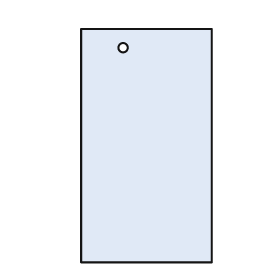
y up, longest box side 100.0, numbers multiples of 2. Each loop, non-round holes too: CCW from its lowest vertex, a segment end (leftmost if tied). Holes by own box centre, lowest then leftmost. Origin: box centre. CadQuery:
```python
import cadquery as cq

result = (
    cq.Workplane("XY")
    .moveTo(-28.0, -50.0)
    .lineTo(28.0, -50.0)
    .lineTo(28.0, 50.0)
    .lineTo(-28.0, 50.0)
    .close()
    .moveTo(-10.0, 42.0)
    .circle(2.0)
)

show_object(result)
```